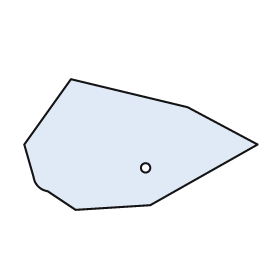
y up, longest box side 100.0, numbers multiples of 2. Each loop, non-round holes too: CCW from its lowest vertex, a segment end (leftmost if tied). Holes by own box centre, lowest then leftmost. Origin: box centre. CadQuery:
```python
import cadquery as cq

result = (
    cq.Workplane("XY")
    .moveTo(-28.0, -28.0)
    .lineTo(4.0, -26.0)
    .lineTo(50.0, 0.0)
    .lineTo(20.0, 16.0)
    .lineTo(-30.0, 28.0)
    .lineTo(-50.0, 0.0)
    .lineTo(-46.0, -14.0)
    .threePointArc((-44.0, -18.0), (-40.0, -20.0))
    .close()
    .moveTo(2.0, -10.0)
    .circle(2.0)
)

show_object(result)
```